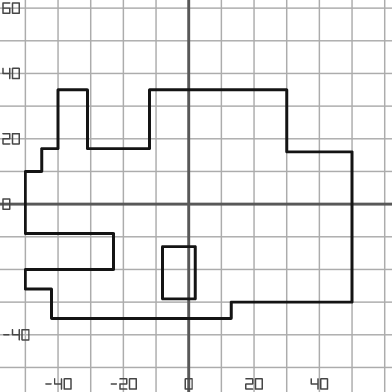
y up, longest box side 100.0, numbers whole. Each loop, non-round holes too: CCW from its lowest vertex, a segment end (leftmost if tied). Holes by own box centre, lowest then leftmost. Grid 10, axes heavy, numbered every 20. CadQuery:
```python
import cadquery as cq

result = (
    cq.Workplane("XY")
    .moveTo(-42.0, -35.0)
    .lineTo(13.0, -35.0)
    .lineTo(13.0, -30.0)
    .lineTo(50.0, -30.0)
    .lineTo(50.0, 16.0)
    .lineTo(30.0, 16.0)
    .lineTo(30.0, 35.0)
    .lineTo(-12.0, 35.0)
    .lineTo(-12.0, 17.0)
    .lineTo(-31.0, 17.0)
    .lineTo(-31.0, 35.0)
    .lineTo(-40.0, 35.0)
    .lineTo(-40.0, 17.0)
    .lineTo(-45.0, 17.0)
    .lineTo(-45.0, 10.0)
    .lineTo(-50.0, 10.0)
    .lineTo(-50.0, -9.0)
    .lineTo(-23.0, -9.0)
    .lineTo(-23.0, -20.0)
    .lineTo(-50.0, -20.0)
    .lineTo(-50.0, -26.0)
    .lineTo(-42.0, -26.0)
    .close()
    .moveTo(-8.0, -29.0)
    .lineTo(2.0, -29.0)
    .lineTo(2.0, -13.0)
    .lineTo(-8.0, -13.0)
    .close()
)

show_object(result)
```